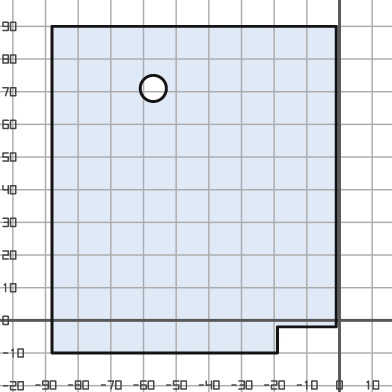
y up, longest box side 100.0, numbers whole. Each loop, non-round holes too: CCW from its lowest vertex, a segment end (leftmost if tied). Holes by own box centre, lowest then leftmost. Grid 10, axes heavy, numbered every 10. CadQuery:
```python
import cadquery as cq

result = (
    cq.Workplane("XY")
    .moveTo(-88.0, -10.0)
    .lineTo(-19.0, -10.0)
    .lineTo(-19.0, -2.0)
    .lineTo(-1.0, -2.0)
    .lineTo(-1.0, 90.0)
    .lineTo(-88.0, 90.0)
    .close()
    .moveTo(-57.0, 71.0)
    .circle(4.0)
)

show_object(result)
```